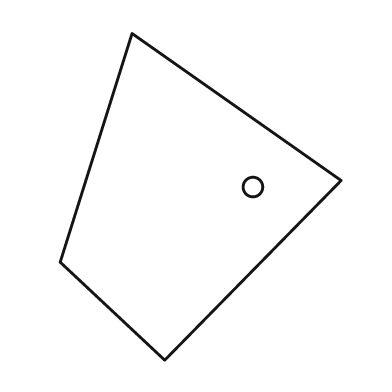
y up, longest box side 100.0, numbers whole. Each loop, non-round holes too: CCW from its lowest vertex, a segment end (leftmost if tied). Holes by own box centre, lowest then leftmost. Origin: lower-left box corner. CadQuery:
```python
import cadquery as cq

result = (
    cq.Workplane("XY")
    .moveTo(32.0, 0.0)
    .lineTo(86.0, 55.0)
    .lineTo(22.0, 100.0)
    .lineTo(0.0, 30.0)
    .close()
    .moveTo(59.0, 53.0)
    .circle(3.0)
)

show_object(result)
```